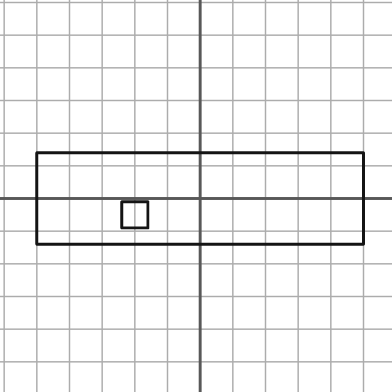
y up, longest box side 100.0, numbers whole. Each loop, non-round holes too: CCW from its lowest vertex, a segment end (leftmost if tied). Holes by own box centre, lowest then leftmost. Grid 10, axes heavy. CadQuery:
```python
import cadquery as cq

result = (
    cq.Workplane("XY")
    .moveTo(-50.0, -14.0)
    .lineTo(50.0, -14.0)
    .lineTo(50.0, 14.0)
    .lineTo(-50.0, 14.0)
    .close()
    .moveTo(-24.0, -9.0)
    .lineTo(-16.0, -9.0)
    .lineTo(-16.0, -1.0)
    .lineTo(-24.0, -1.0)
    .close()
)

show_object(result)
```